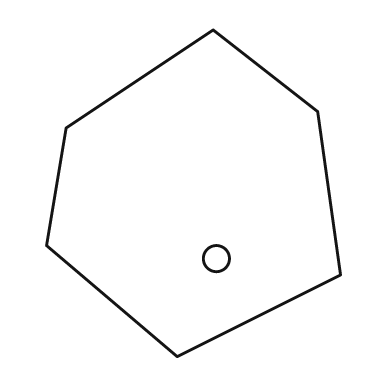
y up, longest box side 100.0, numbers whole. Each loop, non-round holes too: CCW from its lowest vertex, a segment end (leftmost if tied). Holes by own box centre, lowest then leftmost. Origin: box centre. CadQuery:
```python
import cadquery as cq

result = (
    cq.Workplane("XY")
    .moveTo(-5.0, -50.0)
    .lineTo(45.0, -25.0)
    .lineTo(38.0, 25.0)
    .lineTo(6.0, 50.0)
    .lineTo(-39.0, 20.0)
    .lineTo(-45.0, -16.0)
    .close()
    .moveTo(7.0, -20.0)
    .circle(4.0)
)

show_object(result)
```